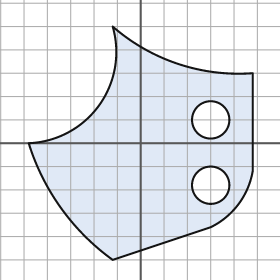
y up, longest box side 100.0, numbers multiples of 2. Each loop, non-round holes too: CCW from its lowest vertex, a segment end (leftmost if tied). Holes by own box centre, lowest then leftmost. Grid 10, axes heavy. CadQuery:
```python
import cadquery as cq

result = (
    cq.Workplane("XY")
    .moveTo(-12.0, -50.0)
    .lineTo(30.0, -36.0)
    .threePointArc((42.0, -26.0), (48.0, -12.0))
    .lineTo(48.0, 30.0)
    .threePointArc((16.0, 34.0), (-12.0, 50.0))
    .threePointArc((-18.0, 16.0), (-48.0, 0.0))
    .threePointArc((-34.0, -28.0), (-12.0, -50.0))
    .close()
    .moveTo(30.0, -18.0)
    .circle(8.0)
    .moveTo(30.0, 10.0)
    .circle(8.0)
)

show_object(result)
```